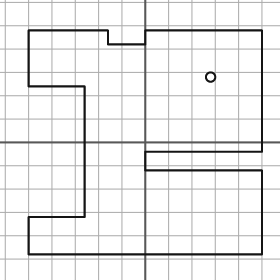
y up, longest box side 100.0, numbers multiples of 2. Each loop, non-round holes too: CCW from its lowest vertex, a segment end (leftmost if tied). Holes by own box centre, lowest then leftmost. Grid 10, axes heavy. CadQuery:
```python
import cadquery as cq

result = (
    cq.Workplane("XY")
    .moveTo(-50.0, -48.0)
    .lineTo(50.0, -48.0)
    .lineTo(50.0, -12.0)
    .lineTo(0.0, -12.0)
    .lineTo(0.0, -4.0)
    .lineTo(50.0, -4.0)
    .lineTo(50.0, 48.0)
    .lineTo(0.0, 48.0)
    .lineTo(0.0, 42.0)
    .lineTo(-16.0, 42.0)
    .lineTo(-16.0, 48.0)
    .lineTo(-50.0, 48.0)
    .lineTo(-50.0, 24.0)
    .lineTo(-26.0, 24.0)
    .lineTo(-26.0, -32.0)
    .lineTo(-50.0, -32.0)
    .close()
    .moveTo(28.0, 28.0)
    .circle(2.0)
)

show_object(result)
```